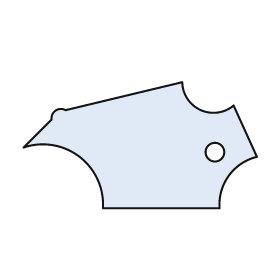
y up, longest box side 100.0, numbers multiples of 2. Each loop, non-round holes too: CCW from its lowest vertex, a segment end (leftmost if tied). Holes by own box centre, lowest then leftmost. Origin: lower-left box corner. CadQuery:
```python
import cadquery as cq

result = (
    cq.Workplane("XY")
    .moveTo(34.0, 0.0)
    .lineTo(84.0, 0.0)
    .threePointArc((88.0, 14.0), (100.0, 22.0))
    .lineTo(90.0, 44.0)
    .threePointArc((76.0, 42.0), (68.0, 54.0))
    .lineTo(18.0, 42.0)
    .threePointArc((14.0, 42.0), (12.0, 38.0))
    .lineTo(0.0, 26.0)
    .threePointArc((24.0, 22.0), (34.0, 0.0))
    .close()
    .moveTo(82.0, 24.0)
    .circle(4.0)
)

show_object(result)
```